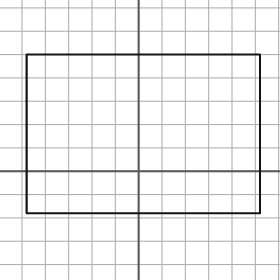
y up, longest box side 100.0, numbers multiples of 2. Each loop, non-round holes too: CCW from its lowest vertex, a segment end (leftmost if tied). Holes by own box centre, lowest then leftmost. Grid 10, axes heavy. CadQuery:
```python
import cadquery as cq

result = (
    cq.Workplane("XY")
    .moveTo(-48.0, -18.0)
    .lineTo(52.0, -18.0)
    .lineTo(52.0, 50.0)
    .lineTo(-48.0, 50.0)
    .close()
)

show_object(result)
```